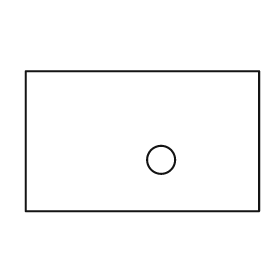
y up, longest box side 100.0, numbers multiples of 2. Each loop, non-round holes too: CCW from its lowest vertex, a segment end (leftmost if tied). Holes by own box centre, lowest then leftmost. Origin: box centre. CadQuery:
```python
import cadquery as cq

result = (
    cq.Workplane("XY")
    .moveTo(-50.0, -30.0)
    .lineTo(50.0, -30.0)
    .lineTo(50.0, 30.0)
    .lineTo(-50.0, 30.0)
    .close()
    .moveTo(8.0, -8.0)
    .circle(6.0)
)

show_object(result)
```